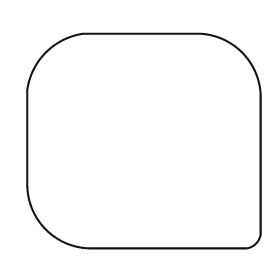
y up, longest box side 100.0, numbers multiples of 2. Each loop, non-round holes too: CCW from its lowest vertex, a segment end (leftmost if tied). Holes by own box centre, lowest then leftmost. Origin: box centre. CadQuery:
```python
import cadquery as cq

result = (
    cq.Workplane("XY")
    .moveTo(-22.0, -46.0)
    .lineTo(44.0, -46.0)
    .threePointArc((48.0, -44.0), (50.0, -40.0))
    .lineTo(50.0, 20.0)
    .threePointArc((42.0, 38.0), (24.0, 46.0))
    .lineTo(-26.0, 46.0)
    .threePointArc((-42.0, 38.0), (-50.0, 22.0))
    .lineTo(-50.0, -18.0)
    .threePointArc((-42.0, -38.0), (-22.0, -46.0))
    .close()
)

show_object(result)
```